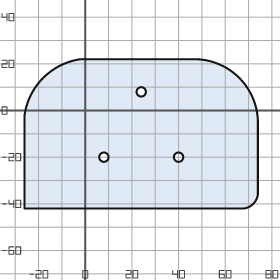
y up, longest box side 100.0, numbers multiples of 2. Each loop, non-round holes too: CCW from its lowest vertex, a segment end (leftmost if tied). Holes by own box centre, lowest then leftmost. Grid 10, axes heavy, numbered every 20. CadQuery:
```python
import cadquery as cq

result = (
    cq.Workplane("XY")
    .moveTo(-26.0, -42.0)
    .lineTo(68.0, -42.0)
    .threePointArc((72.0, -40.0), (74.0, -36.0))
    .lineTo(74.0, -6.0)
    .threePointArc((66.0, 14.0), (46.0, 22.0))
    .lineTo(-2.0, 22.0)
    .threePointArc((-18.0, 14.0), (-26.0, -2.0))
    .close()
    .moveTo(8.0, -20.0)
    .circle(2.0)
    .moveTo(40.0, -20.0)
    .circle(2.0)
    .moveTo(24.0, 8.0)
    .circle(2.0)
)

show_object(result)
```